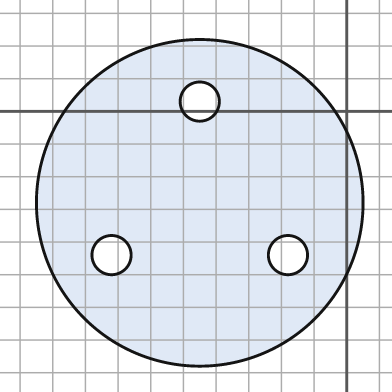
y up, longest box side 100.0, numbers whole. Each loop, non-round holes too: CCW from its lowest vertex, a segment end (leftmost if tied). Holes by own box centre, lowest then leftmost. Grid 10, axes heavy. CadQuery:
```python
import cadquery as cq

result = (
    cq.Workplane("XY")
    .moveTo(-45.0, -28.0)
    .circle(50.0)
    .moveTo(-72.0, -44.0)
    .circle(6.0)
    .moveTo(-18.0, -44.0)
    .circle(6.0)
    .moveTo(-45.0, 3.0)
    .circle(6.0)
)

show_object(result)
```